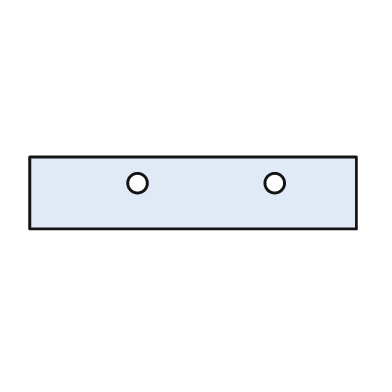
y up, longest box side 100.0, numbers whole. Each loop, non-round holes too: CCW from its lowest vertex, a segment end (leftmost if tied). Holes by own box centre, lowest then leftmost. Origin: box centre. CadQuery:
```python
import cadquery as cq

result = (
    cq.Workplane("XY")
    .moveTo(-50.0, -11.0)
    .lineTo(50.0, -11.0)
    .lineTo(50.0, 11.0)
    .lineTo(-50.0, 11.0)
    .close()
    .moveTo(-17.0, 3.0)
    .circle(3.0)
    .moveTo(25.0, 3.0)
    .circle(3.0)
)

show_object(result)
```